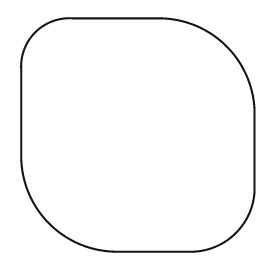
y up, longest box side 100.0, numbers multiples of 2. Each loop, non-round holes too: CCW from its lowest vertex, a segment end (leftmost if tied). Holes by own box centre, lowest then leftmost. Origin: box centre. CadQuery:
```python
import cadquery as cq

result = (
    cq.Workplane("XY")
    .moveTo(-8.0, -50.0)
    .lineTo(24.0, -50.0)
    .threePointArc((42.0, -42.0), (50.0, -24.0))
    .lineTo(50.0, 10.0)
    .threePointArc((38.0, 38.0), (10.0, 50.0))
    .lineTo(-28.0, 50.0)
    .threePointArc((-44.0, 44.0), (-50.0, 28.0))
    .lineTo(-50.0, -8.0)
    .threePointArc((-38.0, -38.0), (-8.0, -50.0))
    .close()
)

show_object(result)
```